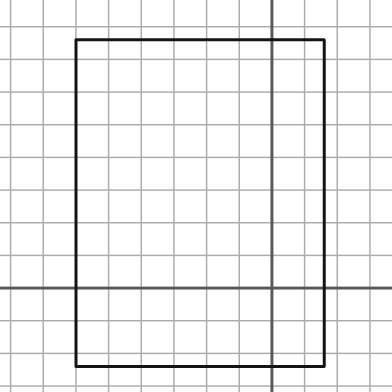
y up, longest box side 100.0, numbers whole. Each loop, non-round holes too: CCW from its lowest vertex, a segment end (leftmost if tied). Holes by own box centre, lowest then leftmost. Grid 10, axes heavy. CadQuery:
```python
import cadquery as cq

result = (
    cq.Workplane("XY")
    .moveTo(-60.0, -24.0)
    .lineTo(16.0, -24.0)
    .lineTo(16.0, 76.0)
    .lineTo(-60.0, 76.0)
    .close()
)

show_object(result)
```